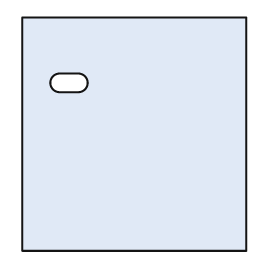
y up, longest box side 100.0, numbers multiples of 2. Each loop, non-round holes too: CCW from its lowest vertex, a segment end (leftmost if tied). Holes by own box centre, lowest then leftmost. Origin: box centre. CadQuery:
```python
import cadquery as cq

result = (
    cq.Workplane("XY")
    .moveTo(-48.0, -50.0)
    .lineTo(48.0, -50.0)
    .lineTo(48.0, 50.0)
    .lineTo(-48.0, 50.0)
    .close()
    .moveTo(-32.0, 18.0)
    .lineTo(-24.0, 18.0)
    .threePointArc((-20.0, 22.0), (-24.0, 26.0))
    .lineTo(-32.0, 26.0)
    .threePointArc((-36.0, 22.0), (-32.0, 18.0))
    .close()
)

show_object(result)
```